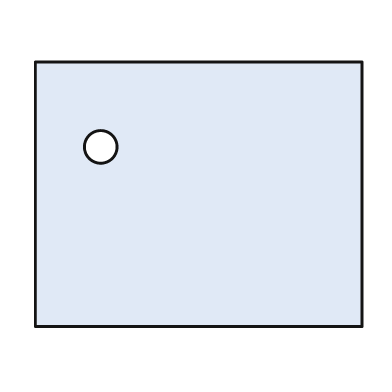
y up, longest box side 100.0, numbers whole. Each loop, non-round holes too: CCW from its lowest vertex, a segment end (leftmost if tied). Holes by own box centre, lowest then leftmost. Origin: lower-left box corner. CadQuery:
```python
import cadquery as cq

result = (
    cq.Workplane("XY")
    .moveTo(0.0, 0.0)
    .lineTo(100.0, 0.0)
    .lineTo(100.0, 81.0)
    .lineTo(0.0, 81.0)
    .close()
    .moveTo(20.0, 55.0)
    .circle(5.0)
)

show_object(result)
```